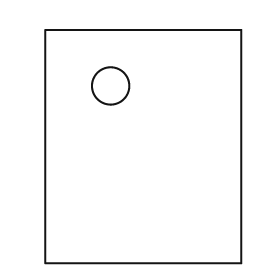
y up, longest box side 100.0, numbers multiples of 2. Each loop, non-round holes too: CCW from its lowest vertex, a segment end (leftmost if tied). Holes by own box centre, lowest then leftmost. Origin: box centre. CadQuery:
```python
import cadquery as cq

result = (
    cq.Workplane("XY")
    .moveTo(-42.0, -50.0)
    .lineTo(42.0, -50.0)
    .lineTo(42.0, 50.0)
    .lineTo(-42.0, 50.0)
    .close()
    .moveTo(-14.0, 26.0)
    .circle(8.0)
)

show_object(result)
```